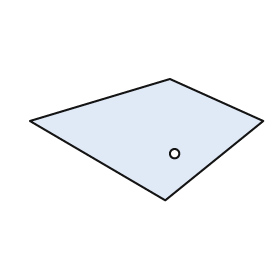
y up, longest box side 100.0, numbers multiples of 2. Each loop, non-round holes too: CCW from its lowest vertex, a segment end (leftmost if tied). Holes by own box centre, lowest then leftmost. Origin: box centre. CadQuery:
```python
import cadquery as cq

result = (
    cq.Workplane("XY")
    .moveTo(8.0, -26.0)
    .lineTo(50.0, 8.0)
    .lineTo(10.0, 26.0)
    .lineTo(-50.0, 8.0)
    .close()
    .moveTo(12.0, -6.0)
    .circle(2.0)
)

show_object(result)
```